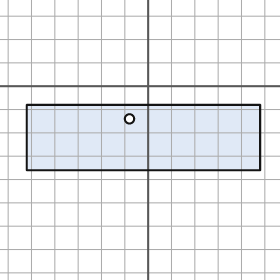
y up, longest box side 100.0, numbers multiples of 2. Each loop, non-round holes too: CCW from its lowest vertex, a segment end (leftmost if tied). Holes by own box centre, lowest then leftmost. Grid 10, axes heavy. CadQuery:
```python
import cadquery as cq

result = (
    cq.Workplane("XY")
    .moveTo(-52.0, -36.0)
    .lineTo(48.0, -36.0)
    .lineTo(48.0, -8.0)
    .lineTo(-52.0, -8.0)
    .close()
    .moveTo(-8.0, -14.0)
    .circle(2.0)
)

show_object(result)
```